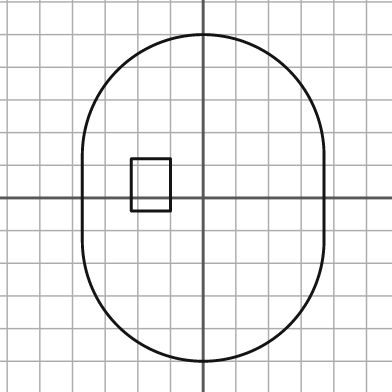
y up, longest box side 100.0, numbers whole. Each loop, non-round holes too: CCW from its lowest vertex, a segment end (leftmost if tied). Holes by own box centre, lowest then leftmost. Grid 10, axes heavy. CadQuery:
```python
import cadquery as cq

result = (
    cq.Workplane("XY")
    .moveTo(-37.0, -13.0)
    .threePointArc((0.0, -50.0), (37.0, -13.0))
    .lineTo(37.0, 13.0)
    .threePointArc((0.0, 50.0), (-37.0, 13.0))
    .close()
    .moveTo(-22.0, -4.0)
    .lineTo(-10.0, -4.0)
    .lineTo(-10.0, 12.0)
    .lineTo(-22.0, 12.0)
    .close()
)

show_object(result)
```